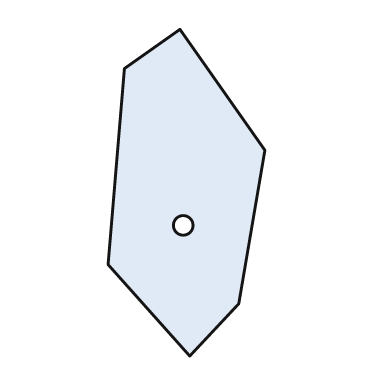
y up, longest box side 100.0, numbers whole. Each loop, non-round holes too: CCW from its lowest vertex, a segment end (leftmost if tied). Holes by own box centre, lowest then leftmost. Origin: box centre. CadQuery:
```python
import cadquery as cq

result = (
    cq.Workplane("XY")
    .moveTo(1.0, -50.0)
    .lineTo(16.0, -34.0)
    .lineTo(24.0, 13.0)
    .lineTo(-2.0, 50.0)
    .lineTo(-19.0, 38.0)
    .lineTo(-24.0, -22.0)
    .close()
    .moveTo(-1.0, -10.0)
    .circle(3.0)
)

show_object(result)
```